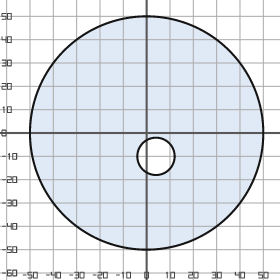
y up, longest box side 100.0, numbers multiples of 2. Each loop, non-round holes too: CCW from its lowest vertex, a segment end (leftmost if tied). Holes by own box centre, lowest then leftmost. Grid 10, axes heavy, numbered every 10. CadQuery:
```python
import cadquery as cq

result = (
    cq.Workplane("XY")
    .moveTo(0.0, 0.0)
    .circle(50.0)
    .moveTo(4.0, -10.0)
    .circle(8.0)
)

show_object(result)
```